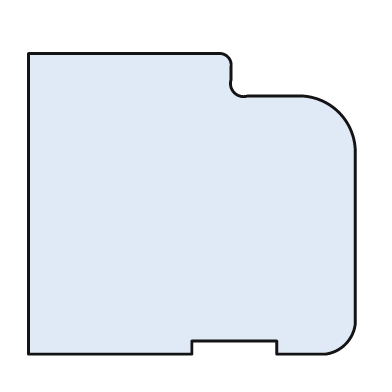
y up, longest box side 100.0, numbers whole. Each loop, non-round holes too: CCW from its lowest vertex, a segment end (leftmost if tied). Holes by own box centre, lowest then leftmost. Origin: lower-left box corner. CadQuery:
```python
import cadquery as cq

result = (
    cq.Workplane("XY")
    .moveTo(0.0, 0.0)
    .lineTo(50.0, 0.0)
    .lineTo(50.0, 4.0)
    .lineTo(76.0, 4.0)
    .lineTo(76.0, 0.0)
    .lineTo(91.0, 0.0)
    .threePointArc((97.0, 3.0), (100.0, 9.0))
    .lineTo(100.0, 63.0)
    .threePointArc((95.0, 74.0), (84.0, 79.0))
    .lineTo(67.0, 79.0)
    .threePointArc((63.0, 80.0), (62.0, 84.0))
    .lineTo(62.0, 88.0)
    .threePointArc((61.0, 91.0), (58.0, 92.0))
    .lineTo(0.0, 92.0)
    .close()
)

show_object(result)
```